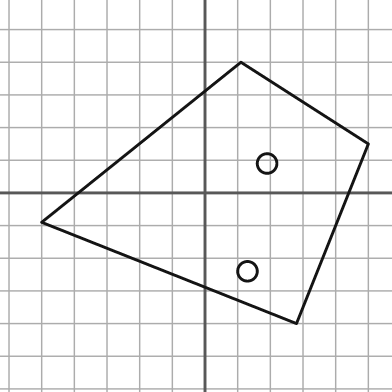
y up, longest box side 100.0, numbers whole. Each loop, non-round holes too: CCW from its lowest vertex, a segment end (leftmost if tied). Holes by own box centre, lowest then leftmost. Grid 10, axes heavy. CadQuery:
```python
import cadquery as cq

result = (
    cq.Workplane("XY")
    .moveTo(28.0, -40.0)
    .lineTo(50.0, 15.0)
    .lineTo(11.0, 40.0)
    .lineTo(-50.0, -9.0)
    .close()
    .moveTo(13.0, -24.0)
    .circle(3.0)
    .moveTo(19.0, 9.0)
    .circle(3.0)
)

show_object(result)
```